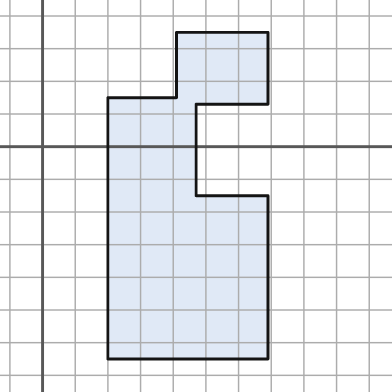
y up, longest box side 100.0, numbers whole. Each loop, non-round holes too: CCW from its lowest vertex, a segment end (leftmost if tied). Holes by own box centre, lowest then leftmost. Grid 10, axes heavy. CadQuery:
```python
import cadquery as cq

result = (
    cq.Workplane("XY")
    .moveTo(20.0, -65.0)
    .lineTo(69.0, -65.0)
    .lineTo(69.0, -15.0)
    .lineTo(47.0, -15.0)
    .lineTo(47.0, 13.0)
    .lineTo(69.0, 13.0)
    .lineTo(69.0, 35.0)
    .lineTo(41.0, 35.0)
    .lineTo(41.0, 15.0)
    .lineTo(20.0, 15.0)
    .close()
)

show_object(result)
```